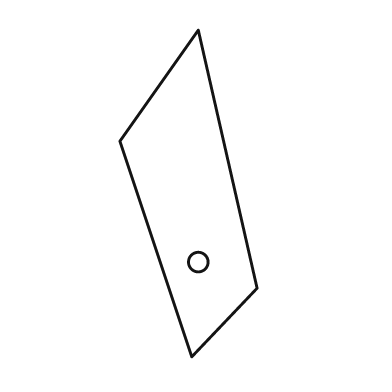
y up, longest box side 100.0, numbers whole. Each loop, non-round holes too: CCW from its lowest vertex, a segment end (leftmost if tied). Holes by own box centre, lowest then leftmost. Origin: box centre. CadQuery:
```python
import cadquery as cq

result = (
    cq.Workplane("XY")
    .moveTo(1.0, -50.0)
    .lineTo(21.0, -29.0)
    .lineTo(3.0, 50.0)
    .lineTo(-21.0, 16.0)
    .close()
    .moveTo(3.0, -21.0)
    .circle(3.0)
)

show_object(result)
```